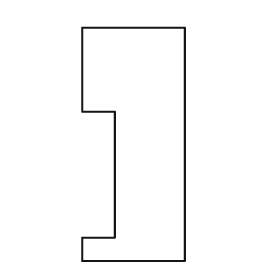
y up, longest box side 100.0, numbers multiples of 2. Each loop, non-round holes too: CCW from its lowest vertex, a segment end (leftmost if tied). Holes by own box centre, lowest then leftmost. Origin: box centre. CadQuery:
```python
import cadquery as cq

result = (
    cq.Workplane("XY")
    .moveTo(-22.0, -50.0)
    .lineTo(22.0, -50.0)
    .lineTo(22.0, 50.0)
    .lineTo(-22.0, 50.0)
    .lineTo(-22.0, 14.0)
    .lineTo(-8.0, 14.0)
    .lineTo(-8.0, -40.0)
    .lineTo(-22.0, -40.0)
    .close()
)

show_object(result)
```